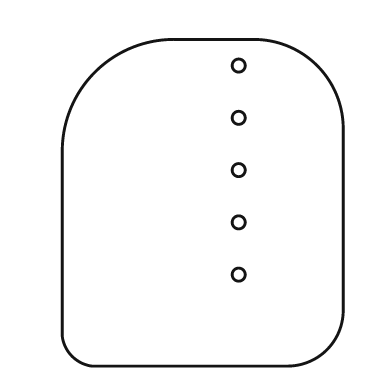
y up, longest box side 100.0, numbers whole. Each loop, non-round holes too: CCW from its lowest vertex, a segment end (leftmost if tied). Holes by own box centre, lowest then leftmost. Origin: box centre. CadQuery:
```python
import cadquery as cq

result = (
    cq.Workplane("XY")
    .moveTo(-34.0, -50.0)
    .lineTo(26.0, -50.0)
    .threePointArc((38.0, -45.0), (43.0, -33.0))
    .lineTo(43.0, 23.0)
    .threePointArc((35.0, 42.0), (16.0, 50.0))
    .lineTo(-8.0, 50.0)
    .threePointArc((-33.0, 40.0), (-43.0, 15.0))
    .lineTo(-43.0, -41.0)
    .threePointArc((-40.0, -47.0), (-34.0, -50.0))
    .close()
    .moveTo(11.0, -22.0)
    .circle(2.0)
    .moveTo(11.0, -6.0)
    .circle(2.0)
    .moveTo(11.0, 10.0)
    .circle(2.0)
    .moveTo(11.0, 26.0)
    .circle(2.0)
    .moveTo(11.0, 42.0)
    .circle(2.0)
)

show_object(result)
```